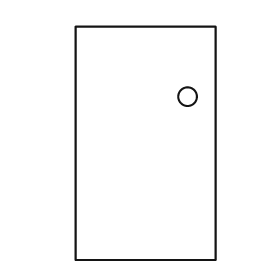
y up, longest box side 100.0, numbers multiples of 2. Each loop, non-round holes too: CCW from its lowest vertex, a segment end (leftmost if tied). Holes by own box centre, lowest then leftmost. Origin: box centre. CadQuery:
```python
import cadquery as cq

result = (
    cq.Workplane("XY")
    .moveTo(-30.0, -50.0)
    .lineTo(30.0, -50.0)
    .lineTo(30.0, 50.0)
    .lineTo(-30.0, 50.0)
    .close()
    .moveTo(18.0, 20.0)
    .circle(4.0)
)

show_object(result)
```